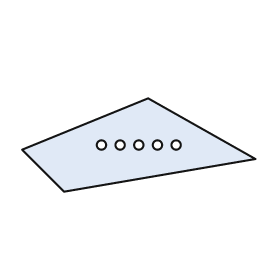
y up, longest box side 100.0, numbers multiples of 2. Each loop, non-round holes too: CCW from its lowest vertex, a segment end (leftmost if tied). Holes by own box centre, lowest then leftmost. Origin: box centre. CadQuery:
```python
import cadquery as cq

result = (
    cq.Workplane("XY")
    .moveTo(-32.0, -20.0)
    .lineTo(50.0, -6.0)
    .lineTo(4.0, 20.0)
    .lineTo(-50.0, -2.0)
    .close()
    .moveTo(-16.0, 0.0)
    .circle(2.0)
    .moveTo(-8.0, 0.0)
    .circle(2.0)
    .moveTo(0.0, 0.0)
    .circle(2.0)
    .moveTo(8.0, 0.0)
    .circle(2.0)
    .moveTo(16.0, 0.0)
    .circle(2.0)
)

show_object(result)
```